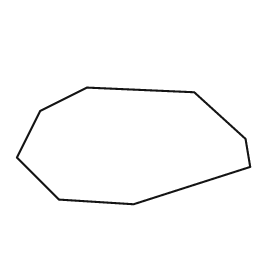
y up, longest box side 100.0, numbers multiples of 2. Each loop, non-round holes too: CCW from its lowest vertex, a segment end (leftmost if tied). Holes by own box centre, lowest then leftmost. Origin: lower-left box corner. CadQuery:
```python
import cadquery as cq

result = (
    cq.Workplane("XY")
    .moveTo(50.0, 0.0)
    .lineTo(100.0, 16.0)
    .lineTo(98.0, 28.0)
    .lineTo(76.0, 48.0)
    .lineTo(30.0, 50.0)
    .lineTo(10.0, 40.0)
    .lineTo(0.0, 20.0)
    .lineTo(18.0, 2.0)
    .close()
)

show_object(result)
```